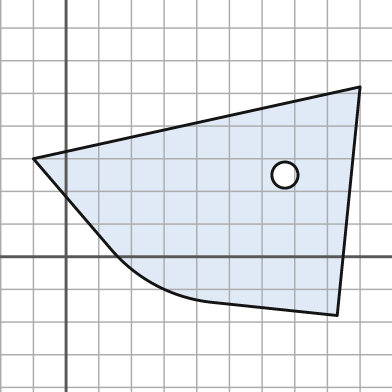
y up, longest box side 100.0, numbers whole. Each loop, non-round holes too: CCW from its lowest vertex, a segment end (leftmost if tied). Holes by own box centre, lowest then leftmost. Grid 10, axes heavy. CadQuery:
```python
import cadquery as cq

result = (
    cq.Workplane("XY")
    .moveTo(83.0, -18.0)
    .lineTo(90.0, 52.0)
    .lineTo(-10.0, 30.0)
    .lineTo(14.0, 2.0)
    .threePointArc((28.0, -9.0), (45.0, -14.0))
    .close()
    .moveTo(67.0, 25.0)
    .circle(4.0)
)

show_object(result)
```